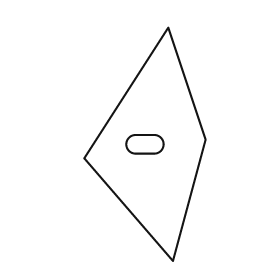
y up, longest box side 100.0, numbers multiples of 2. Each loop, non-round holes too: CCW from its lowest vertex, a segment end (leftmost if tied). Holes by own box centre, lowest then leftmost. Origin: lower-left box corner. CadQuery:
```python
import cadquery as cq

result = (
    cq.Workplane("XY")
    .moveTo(38.0, 0.0)
    .lineTo(52.0, 52.0)
    .lineTo(36.0, 100.0)
    .lineTo(0.0, 44.0)
    .close()
    .moveTo(22.0, 46.0)
    .lineTo(30.0, 46.0)
    .threePointArc((34.0, 50.0), (30.0, 54.0))
    .lineTo(22.0, 54.0)
    .threePointArc((18.0, 50.0), (22.0, 46.0))
    .close()
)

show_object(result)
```